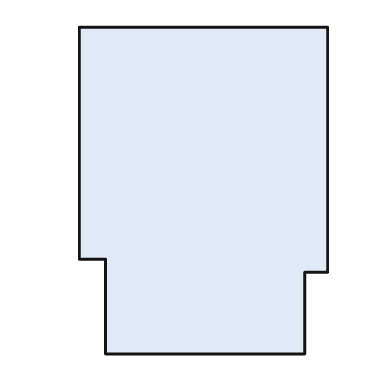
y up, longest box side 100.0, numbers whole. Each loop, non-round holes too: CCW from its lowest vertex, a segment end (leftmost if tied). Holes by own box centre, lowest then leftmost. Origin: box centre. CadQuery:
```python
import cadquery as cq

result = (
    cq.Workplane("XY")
    .moveTo(-30.0, -50.0)
    .lineTo(31.0, -50.0)
    .lineTo(31.0, -25.0)
    .lineTo(38.0, -25.0)
    .lineTo(38.0, 50.0)
    .lineTo(-38.0, 50.0)
    .lineTo(-38.0, -21.0)
    .lineTo(-30.0, -21.0)
    .close()
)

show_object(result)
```